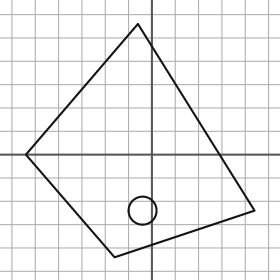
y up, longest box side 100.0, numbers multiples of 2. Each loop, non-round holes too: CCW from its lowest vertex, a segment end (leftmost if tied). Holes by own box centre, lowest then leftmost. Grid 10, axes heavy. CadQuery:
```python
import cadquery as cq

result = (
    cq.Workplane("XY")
    .moveTo(-16.0, -44.0)
    .lineTo(44.0, -24.0)
    .lineTo(-6.0, 56.0)
    .lineTo(-54.0, 0.0)
    .close()
    .moveTo(-4.0, -24.0)
    .circle(6.0)
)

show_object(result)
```